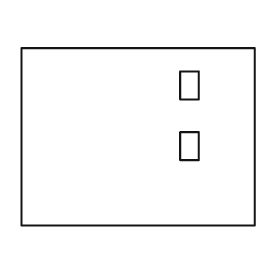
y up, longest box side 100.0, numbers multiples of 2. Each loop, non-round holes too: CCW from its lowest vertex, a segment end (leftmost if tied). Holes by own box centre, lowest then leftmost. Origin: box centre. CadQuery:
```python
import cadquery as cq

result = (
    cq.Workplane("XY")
    .moveTo(-50.0, -38.0)
    .lineTo(50.0, -38.0)
    .lineTo(50.0, 38.0)
    .lineTo(-50.0, 38.0)
    .close()
    .moveTo(18.0, -10.0)
    .lineTo(26.0, -10.0)
    .lineTo(26.0, 2.0)
    .lineTo(18.0, 2.0)
    .close()
    .moveTo(18.0, 16.0)
    .lineTo(26.0, 16.0)
    .lineTo(26.0, 28.0)
    .lineTo(18.0, 28.0)
    .close()
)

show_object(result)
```